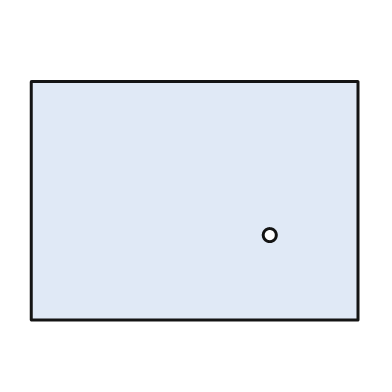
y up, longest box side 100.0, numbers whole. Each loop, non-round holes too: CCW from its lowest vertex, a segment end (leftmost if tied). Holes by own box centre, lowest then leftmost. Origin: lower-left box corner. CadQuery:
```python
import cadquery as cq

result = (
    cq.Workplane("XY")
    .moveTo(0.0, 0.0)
    .lineTo(100.0, 0.0)
    .lineTo(100.0, 73.0)
    .lineTo(0.0, 73.0)
    .close()
    .moveTo(73.0, 26.0)
    .circle(2.0)
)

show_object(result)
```